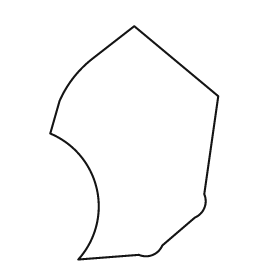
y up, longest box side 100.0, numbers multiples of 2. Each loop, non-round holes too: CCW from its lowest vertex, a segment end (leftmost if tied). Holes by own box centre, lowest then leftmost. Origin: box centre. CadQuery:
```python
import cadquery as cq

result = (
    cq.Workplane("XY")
    .moveTo(-24.0, -50.0)
    .lineTo(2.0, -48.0)
    .threePointArc((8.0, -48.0), (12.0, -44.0))
    .lineTo(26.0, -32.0)
    .threePointArc((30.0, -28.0), (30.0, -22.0))
    .lineTo(36.0, 20.0)
    .lineTo(0.0, 50.0)
    .lineTo(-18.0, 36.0)
    .threePointArc((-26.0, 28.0), (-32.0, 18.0))
    .lineTo(-36.0, 4.0)
    .threePointArc((-16.0, -20.0), (-24.0, -50.0))
    .close()
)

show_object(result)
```